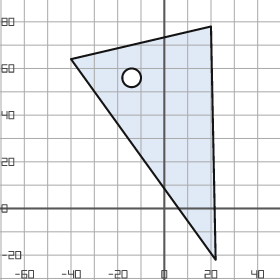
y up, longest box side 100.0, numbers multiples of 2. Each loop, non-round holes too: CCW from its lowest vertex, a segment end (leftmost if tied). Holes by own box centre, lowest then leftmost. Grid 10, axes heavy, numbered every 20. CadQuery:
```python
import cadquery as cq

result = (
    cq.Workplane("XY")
    .moveTo(22.0, -22.0)
    .lineTo(20.0, 78.0)
    .lineTo(-40.0, 64.0)
    .close()
    .moveTo(-14.0, 56.0)
    .circle(4.0)
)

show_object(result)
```